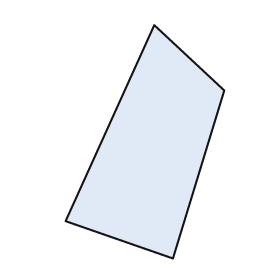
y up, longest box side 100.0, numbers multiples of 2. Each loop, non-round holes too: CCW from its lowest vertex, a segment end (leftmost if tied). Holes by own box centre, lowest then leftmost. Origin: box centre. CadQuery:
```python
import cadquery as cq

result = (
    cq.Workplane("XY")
    .moveTo(12.0, -50.0)
    .lineTo(34.0, 22.0)
    .lineTo(4.0, 50.0)
    .lineTo(-34.0, -34.0)
    .close()
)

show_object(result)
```